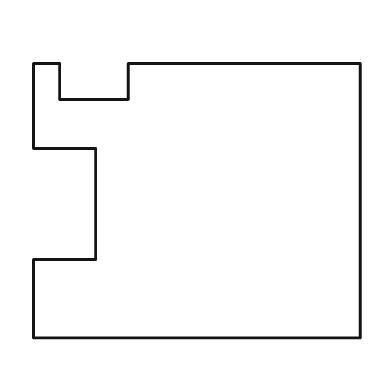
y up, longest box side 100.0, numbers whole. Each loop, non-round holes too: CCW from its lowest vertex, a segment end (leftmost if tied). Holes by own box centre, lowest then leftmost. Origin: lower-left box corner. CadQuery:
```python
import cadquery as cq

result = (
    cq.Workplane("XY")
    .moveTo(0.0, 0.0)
    .lineTo(100.0, 0.0)
    .lineTo(100.0, 84.0)
    .lineTo(29.0, 84.0)
    .lineTo(29.0, 73.0)
    .lineTo(8.0, 73.0)
    .lineTo(8.0, 84.0)
    .lineTo(0.0, 84.0)
    .lineTo(0.0, 58.0)
    .lineTo(19.0, 58.0)
    .lineTo(19.0, 24.0)
    .lineTo(0.0, 24.0)
    .close()
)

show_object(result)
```